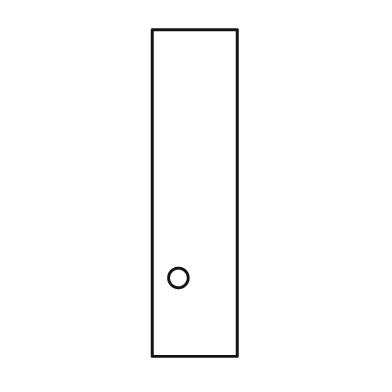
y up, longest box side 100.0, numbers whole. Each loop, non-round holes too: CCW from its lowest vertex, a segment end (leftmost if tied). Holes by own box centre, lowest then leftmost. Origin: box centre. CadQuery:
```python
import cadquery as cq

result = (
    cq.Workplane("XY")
    .moveTo(-13.0, -50.0)
    .lineTo(13.0, -50.0)
    .lineTo(13.0, 50.0)
    .lineTo(-13.0, 50.0)
    .close()
    .moveTo(-5.0, -26.0)
    .circle(3.0)
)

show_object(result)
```